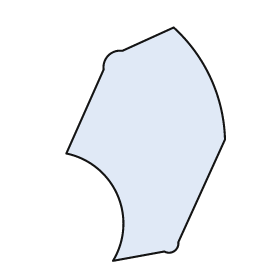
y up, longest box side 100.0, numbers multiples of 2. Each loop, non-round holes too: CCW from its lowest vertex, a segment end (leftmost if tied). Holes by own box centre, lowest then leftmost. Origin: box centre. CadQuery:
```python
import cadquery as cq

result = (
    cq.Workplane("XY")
    .moveTo(-14.0, -50.0)
    .lineTo(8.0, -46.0)
    .threePointArc((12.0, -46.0), (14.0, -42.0))
    .lineTo(34.0, 2.0)
    .threePointArc((28.0, 28.0), (12.0, 50.0))
    .lineTo(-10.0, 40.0)
    .threePointArc((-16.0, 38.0), (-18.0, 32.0))
    .lineTo(-34.0, -4.0)
    .threePointArc((-12.0, -22.0), (-14.0, -50.0))
    .close()
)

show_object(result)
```